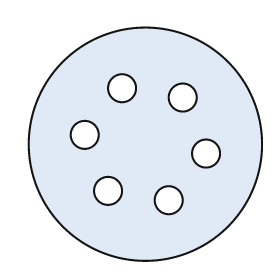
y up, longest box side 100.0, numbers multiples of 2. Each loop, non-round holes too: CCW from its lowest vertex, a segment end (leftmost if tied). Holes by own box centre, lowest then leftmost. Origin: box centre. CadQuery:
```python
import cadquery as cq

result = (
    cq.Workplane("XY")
    .moveTo(0.0, 0.0)
    .circle(50.0)
    .moveTo(10.0, -24.0)
    .circle(6.0)
    .moveTo(-16.0, -20.0)
    .circle(6.0)
    .moveTo(26.0, -4.0)
    .circle(6.0)
    .moveTo(-26.0, 4.0)
    .circle(6.0)
    .moveTo(16.0, 20.0)
    .circle(6.0)
    .moveTo(-10.0, 24.0)
    .circle(6.0)
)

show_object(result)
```